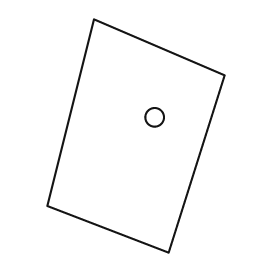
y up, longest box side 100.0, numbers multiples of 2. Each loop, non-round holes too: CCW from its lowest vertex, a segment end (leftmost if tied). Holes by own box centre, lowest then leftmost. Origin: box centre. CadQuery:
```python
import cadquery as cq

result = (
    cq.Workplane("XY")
    .moveTo(14.0, -50.0)
    .lineTo(38.0, 26.0)
    .lineTo(-18.0, 50.0)
    .lineTo(-38.0, -30.0)
    .close()
    .moveTo(8.0, 8.0)
    .circle(4.0)
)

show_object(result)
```